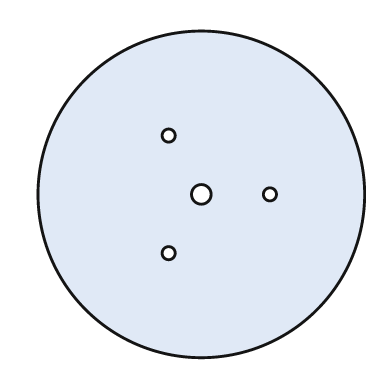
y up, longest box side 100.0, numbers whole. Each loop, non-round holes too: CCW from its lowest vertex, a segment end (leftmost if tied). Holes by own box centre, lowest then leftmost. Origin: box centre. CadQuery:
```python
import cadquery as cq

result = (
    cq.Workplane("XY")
    .moveTo(0.0, 0.0)
    .circle(50.0)
    .moveTo(-10.0, -18.0)
    .circle(2.0)
    .moveTo(0.0, 0.0)
    .circle(3.0)
    .moveTo(21.0, 0.0)
    .circle(2.0)
    .moveTo(-10.0, 18.0)
    .circle(2.0)
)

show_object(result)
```